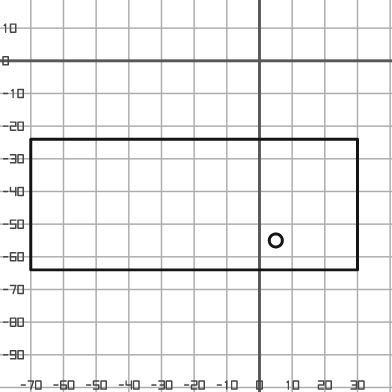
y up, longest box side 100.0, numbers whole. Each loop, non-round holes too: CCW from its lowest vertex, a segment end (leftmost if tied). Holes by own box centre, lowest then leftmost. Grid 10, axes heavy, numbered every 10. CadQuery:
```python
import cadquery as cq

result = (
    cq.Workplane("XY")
    .moveTo(-70.0, -64.0)
    .lineTo(30.0, -64.0)
    .lineTo(30.0, -24.0)
    .lineTo(-70.0, -24.0)
    .close()
    .moveTo(5.0, -55.0)
    .circle(2.0)
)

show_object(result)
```